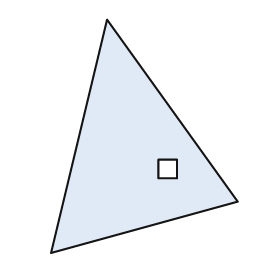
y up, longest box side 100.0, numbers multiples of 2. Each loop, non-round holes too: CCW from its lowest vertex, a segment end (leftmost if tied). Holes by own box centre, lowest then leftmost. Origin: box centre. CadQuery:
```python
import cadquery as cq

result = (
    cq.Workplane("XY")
    .moveTo(-40.0, -50.0)
    .lineTo(40.0, -28.0)
    .lineTo(-16.0, 50.0)
    .close()
    .moveTo(6.0, -18.0)
    .lineTo(14.0, -18.0)
    .lineTo(14.0, -10.0)
    .lineTo(6.0, -10.0)
    .close()
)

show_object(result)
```